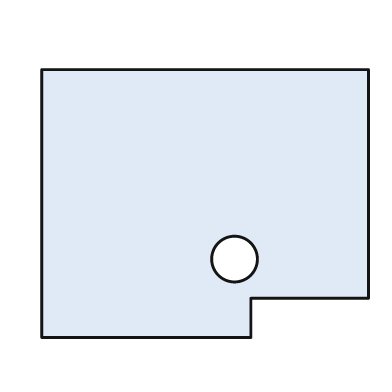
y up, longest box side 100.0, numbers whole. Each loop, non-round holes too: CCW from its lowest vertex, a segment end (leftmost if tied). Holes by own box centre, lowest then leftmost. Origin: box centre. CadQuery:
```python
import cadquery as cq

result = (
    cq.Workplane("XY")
    .moveTo(-50.0, -41.0)
    .lineTo(14.0, -41.0)
    .lineTo(14.0, -29.0)
    .lineTo(50.0, -29.0)
    .lineTo(50.0, 41.0)
    .lineTo(-50.0, 41.0)
    .close()
    .moveTo(9.0, -17.0)
    .circle(7.0)
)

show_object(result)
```